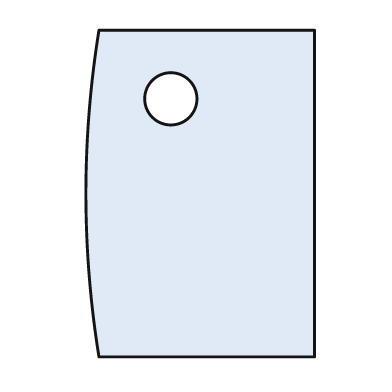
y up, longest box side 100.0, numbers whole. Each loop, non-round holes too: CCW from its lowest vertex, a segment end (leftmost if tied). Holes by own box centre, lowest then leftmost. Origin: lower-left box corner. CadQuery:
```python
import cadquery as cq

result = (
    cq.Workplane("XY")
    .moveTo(4.0, 0.0)
    .lineTo(70.0, 0.0)
    .lineTo(70.0, 100.0)
    .lineTo(4.0, 100.0)
    .threePointArc((0.0, 50.0), (4.0, 0.0))
    .close()
    .moveTo(26.0, 79.0)
    .circle(8.0)
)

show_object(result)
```